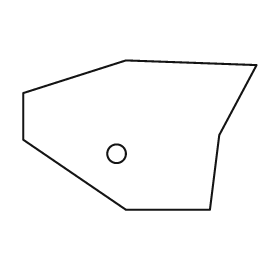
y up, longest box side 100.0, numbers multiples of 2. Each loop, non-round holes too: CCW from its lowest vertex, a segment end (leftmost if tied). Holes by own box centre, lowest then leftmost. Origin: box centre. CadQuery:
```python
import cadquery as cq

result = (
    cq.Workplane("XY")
    .moveTo(-6.0, -32.0)
    .lineTo(30.0, -32.0)
    .lineTo(34.0, 0.0)
    .lineTo(50.0, 30.0)
    .lineTo(-6.0, 32.0)
    .lineTo(-50.0, 18.0)
    .lineTo(-50.0, -2.0)
    .close()
    .moveTo(-10.0, -8.0)
    .circle(4.0)
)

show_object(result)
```